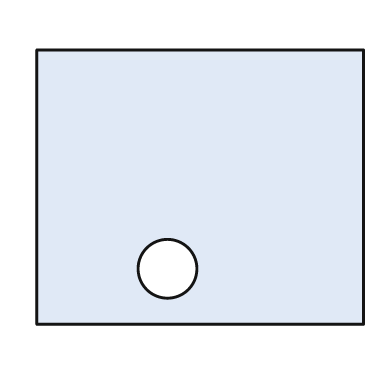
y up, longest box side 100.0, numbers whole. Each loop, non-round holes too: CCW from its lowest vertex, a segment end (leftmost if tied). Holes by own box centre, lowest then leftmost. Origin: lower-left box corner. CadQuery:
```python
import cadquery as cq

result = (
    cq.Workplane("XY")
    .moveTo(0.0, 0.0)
    .lineTo(100.0, 0.0)
    .lineTo(100.0, 84.0)
    .lineTo(0.0, 84.0)
    .close()
    .moveTo(40.0, 17.0)
    .circle(9.0)
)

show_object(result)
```